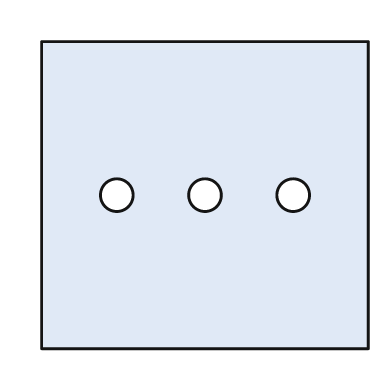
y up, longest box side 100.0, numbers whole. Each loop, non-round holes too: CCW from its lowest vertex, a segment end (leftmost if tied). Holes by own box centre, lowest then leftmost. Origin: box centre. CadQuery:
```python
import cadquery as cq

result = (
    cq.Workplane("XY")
    .moveTo(-50.0, -47.0)
    .lineTo(50.0, -47.0)
    .lineTo(50.0, 47.0)
    .lineTo(-50.0, 47.0)
    .close()
    .moveTo(-27.0, 0.0)
    .circle(5.0)
    .moveTo(0.0, 0.0)
    .circle(5.0)
    .moveTo(27.0, 0.0)
    .circle(5.0)
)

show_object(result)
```